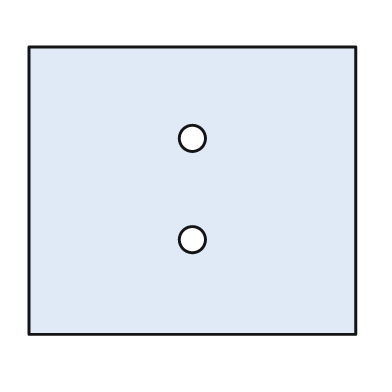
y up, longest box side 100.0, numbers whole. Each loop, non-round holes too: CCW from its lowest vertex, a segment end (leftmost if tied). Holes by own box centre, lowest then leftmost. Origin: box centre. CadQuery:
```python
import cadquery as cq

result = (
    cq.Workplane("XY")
    .moveTo(-50.0, -44.0)
    .lineTo(50.0, -44.0)
    .lineTo(50.0, 44.0)
    .lineTo(-50.0, 44.0)
    .close()
    .moveTo(0.0, -15.0)
    .circle(4.0)
    .moveTo(0.0, 16.0)
    .circle(4.0)
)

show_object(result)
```